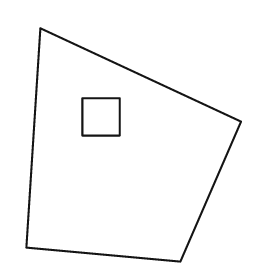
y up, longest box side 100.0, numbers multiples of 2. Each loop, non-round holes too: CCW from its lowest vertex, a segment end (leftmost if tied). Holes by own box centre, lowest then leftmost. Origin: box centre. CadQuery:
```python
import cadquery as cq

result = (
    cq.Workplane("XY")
    .moveTo(20.0, -50.0)
    .lineTo(46.0, 10.0)
    .lineTo(-40.0, 50.0)
    .lineTo(-46.0, -44.0)
    .close()
    .moveTo(-22.0, 4.0)
    .lineTo(-6.0, 4.0)
    .lineTo(-6.0, 20.0)
    .lineTo(-22.0, 20.0)
    .close()
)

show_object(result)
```